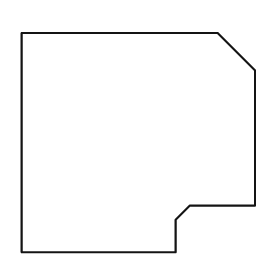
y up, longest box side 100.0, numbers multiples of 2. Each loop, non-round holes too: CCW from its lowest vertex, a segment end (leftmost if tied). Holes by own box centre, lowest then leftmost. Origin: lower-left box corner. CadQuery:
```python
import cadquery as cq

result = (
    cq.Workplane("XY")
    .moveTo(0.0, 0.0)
    .lineTo(66.0, 0.0)
    .lineTo(66.0, 14.0)
    .lineTo(72.0, 20.0)
    .lineTo(100.0, 20.0)
    .lineTo(100.0, 78.0)
    .lineTo(84.0, 94.0)
    .lineTo(0.0, 94.0)
    .close()
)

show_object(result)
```